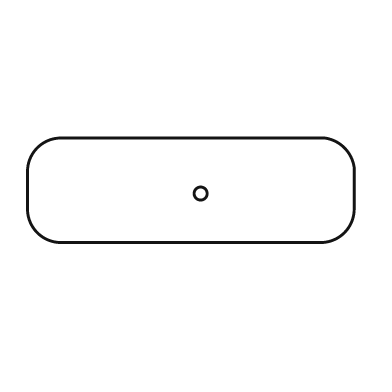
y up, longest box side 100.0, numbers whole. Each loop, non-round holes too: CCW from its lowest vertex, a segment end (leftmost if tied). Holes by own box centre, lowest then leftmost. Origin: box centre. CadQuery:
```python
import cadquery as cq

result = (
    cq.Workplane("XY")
    .moveTo(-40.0, -16.0)
    .lineTo(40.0, -16.0)
    .threePointArc((47.0, -13.0), (50.0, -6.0))
    .lineTo(50.0, 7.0)
    .threePointArc((47.0, 13.0), (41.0, 16.0))
    .lineTo(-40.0, 16.0)
    .threePointArc((-47.0, 13.0), (-50.0, 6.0))
    .lineTo(-50.0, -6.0)
    .threePointArc((-47.0, -13.0), (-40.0, -16.0))
    .close()
    .moveTo(3.0, -1.0)
    .circle(2.0)
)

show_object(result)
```